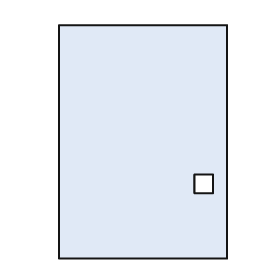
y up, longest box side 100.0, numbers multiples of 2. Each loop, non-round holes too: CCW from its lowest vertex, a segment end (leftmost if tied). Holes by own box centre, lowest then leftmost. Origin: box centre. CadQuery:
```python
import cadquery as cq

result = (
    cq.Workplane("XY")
    .moveTo(-36.0, -50.0)
    .lineTo(36.0, -50.0)
    .lineTo(36.0, 50.0)
    .lineTo(-36.0, 50.0)
    .close()
    .moveTo(22.0, -22.0)
    .lineTo(30.0, -22.0)
    .lineTo(30.0, -14.0)
    .lineTo(22.0, -14.0)
    .close()
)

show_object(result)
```